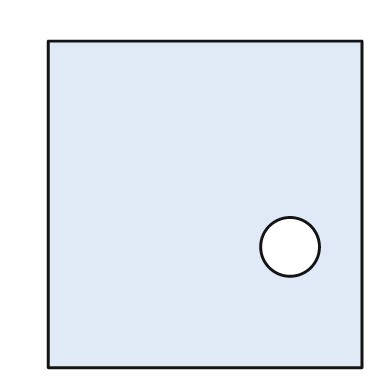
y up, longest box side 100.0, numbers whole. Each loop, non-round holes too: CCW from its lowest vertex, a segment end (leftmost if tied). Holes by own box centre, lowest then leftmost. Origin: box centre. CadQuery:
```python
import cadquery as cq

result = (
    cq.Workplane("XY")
    .moveTo(-48.0, -50.0)
    .lineTo(48.0, -50.0)
    .lineTo(48.0, 50.0)
    .lineTo(-48.0, 50.0)
    .close()
    .moveTo(26.0, -13.0)
    .circle(9.0)
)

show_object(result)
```